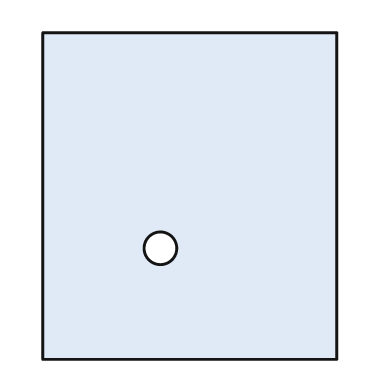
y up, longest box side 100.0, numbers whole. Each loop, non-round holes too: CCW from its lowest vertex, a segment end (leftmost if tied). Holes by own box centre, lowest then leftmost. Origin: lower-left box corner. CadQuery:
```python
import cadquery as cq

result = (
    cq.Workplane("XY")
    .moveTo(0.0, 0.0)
    .lineTo(90.0, 0.0)
    .lineTo(90.0, 100.0)
    .lineTo(0.0, 100.0)
    .close()
    .moveTo(36.0, 34.0)
    .circle(5.0)
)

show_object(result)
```